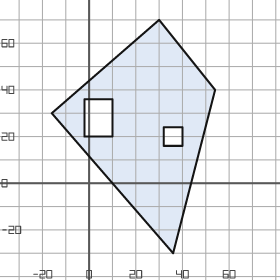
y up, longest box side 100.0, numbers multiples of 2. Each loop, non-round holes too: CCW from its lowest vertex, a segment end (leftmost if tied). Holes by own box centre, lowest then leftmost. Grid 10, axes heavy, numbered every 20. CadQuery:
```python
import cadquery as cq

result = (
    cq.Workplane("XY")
    .moveTo(36.0, -30.0)
    .lineTo(54.0, 40.0)
    .lineTo(30.0, 70.0)
    .lineTo(-16.0, 30.0)
    .close()
    .moveTo(32.0, 16.0)
    .lineTo(40.0, 16.0)
    .lineTo(40.0, 24.0)
    .lineTo(32.0, 24.0)
    .close()
    .moveTo(-2.0, 20.0)
    .lineTo(10.0, 20.0)
    .lineTo(10.0, 36.0)
    .lineTo(-2.0, 36.0)
    .close()
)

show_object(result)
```